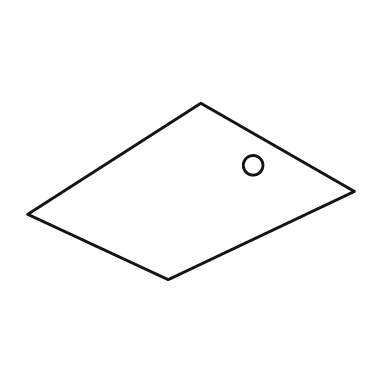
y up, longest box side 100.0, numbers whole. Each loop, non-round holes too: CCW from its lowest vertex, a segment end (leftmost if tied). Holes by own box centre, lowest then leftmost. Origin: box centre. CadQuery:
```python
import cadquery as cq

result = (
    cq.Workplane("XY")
    .moveTo(-7.0, -27.0)
    .lineTo(50.0, 0.0)
    .lineTo(3.0, 27.0)
    .lineTo(-50.0, -7.0)
    .close()
    .moveTo(19.0, 8.0)
    .circle(3.0)
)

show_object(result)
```